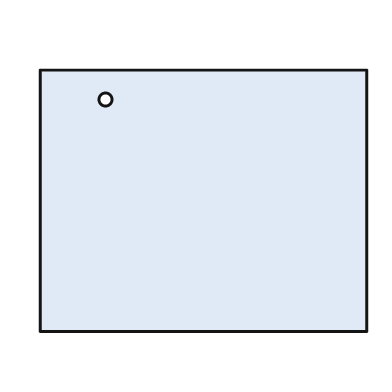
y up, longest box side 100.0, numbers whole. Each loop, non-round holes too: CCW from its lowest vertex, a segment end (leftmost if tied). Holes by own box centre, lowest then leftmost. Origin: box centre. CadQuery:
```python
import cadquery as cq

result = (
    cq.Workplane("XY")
    .moveTo(-50.0, -40.0)
    .lineTo(50.0, -40.0)
    .lineTo(50.0, 40.0)
    .lineTo(-50.0, 40.0)
    .close()
    .moveTo(-30.0, 31.0)
    .circle(2.0)
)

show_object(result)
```